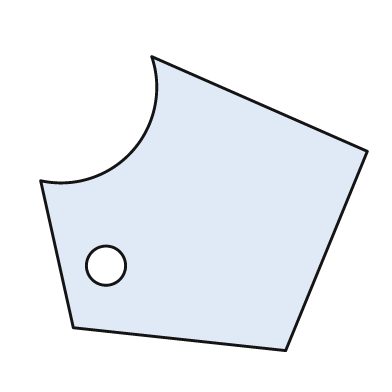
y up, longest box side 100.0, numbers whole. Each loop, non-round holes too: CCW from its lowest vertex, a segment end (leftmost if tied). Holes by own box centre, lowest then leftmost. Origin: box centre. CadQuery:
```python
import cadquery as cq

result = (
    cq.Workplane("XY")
    .moveTo(25.0, -45.0)
    .lineTo(50.0, 16.0)
    .lineTo(-16.0, 45.0)
    .threePointArc((-22.0, 16.0), (-50.0, 7.0))
    .lineTo(-40.0, -38.0)
    .close()
    .moveTo(-30.0, -19.0)
    .circle(6.0)
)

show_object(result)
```